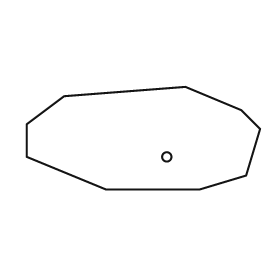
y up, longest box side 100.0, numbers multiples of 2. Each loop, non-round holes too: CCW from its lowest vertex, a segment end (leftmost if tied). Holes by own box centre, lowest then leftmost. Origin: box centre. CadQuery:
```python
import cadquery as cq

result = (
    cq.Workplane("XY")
    .moveTo(-16.0, -22.0)
    .lineTo(24.0, -22.0)
    .lineTo(44.0, -16.0)
    .lineTo(50.0, 4.0)
    .lineTo(42.0, 12.0)
    .lineTo(18.0, 22.0)
    .lineTo(-34.0, 18.0)
    .lineTo(-50.0, 6.0)
    .lineTo(-50.0, -8.0)
    .close()
    .moveTo(10.0, -8.0)
    .circle(2.0)
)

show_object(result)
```